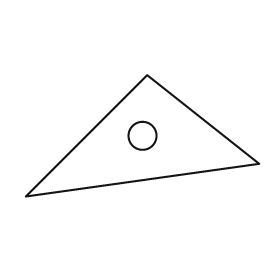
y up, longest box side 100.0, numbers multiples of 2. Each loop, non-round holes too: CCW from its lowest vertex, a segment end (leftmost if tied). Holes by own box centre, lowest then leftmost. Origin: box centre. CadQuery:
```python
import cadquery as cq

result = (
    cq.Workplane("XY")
    .moveTo(-50.0, -26.0)
    .lineTo(50.0, -12.0)
    .lineTo(2.0, 26.0)
    .close()
    .moveTo(0.0, 0.0)
    .circle(6.0)
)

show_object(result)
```